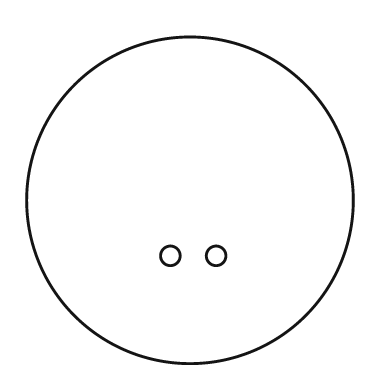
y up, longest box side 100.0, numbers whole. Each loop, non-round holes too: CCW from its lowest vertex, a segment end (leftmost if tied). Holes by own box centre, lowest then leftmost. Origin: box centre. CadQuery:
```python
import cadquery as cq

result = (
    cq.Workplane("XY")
    .moveTo(0.0, 0.0)
    .circle(50.0)
    .moveTo(-6.0, -17.0)
    .circle(3.0)
    .moveTo(8.0, -17.0)
    .circle(3.0)
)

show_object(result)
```